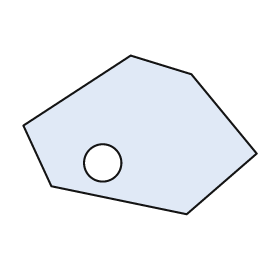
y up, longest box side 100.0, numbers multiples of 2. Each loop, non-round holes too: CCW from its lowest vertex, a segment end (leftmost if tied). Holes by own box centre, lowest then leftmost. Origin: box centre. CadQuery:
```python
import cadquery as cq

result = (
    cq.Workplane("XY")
    .moveTo(20.0, -34.0)
    .lineTo(50.0, -8.0)
    .lineTo(22.0, 26.0)
    .lineTo(-4.0, 34.0)
    .lineTo(-50.0, 4.0)
    .lineTo(-38.0, -22.0)
    .close()
    .moveTo(-16.0, -12.0)
    .circle(8.0)
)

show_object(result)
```